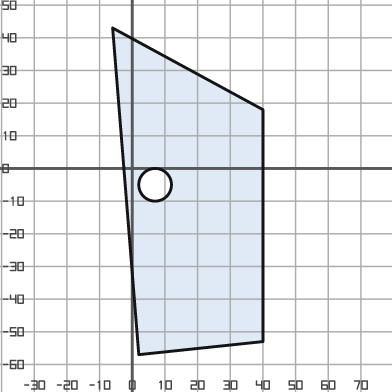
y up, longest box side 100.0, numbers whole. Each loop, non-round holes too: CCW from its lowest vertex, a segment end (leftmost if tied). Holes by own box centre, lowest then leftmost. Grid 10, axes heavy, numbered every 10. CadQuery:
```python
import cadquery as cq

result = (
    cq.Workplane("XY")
    .moveTo(2.0, -57.0)
    .lineTo(40.0, -53.0)
    .lineTo(40.0, 18.0)
    .lineTo(-6.0, 43.0)
    .close()
    .moveTo(7.0, -5.0)
    .circle(5.0)
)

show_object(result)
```